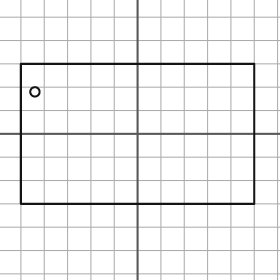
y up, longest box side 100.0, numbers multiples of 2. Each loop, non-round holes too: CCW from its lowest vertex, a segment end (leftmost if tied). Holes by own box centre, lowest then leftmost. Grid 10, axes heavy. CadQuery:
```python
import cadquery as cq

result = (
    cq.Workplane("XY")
    .moveTo(-50.0, -30.0)
    .lineTo(50.0, -30.0)
    .lineTo(50.0, 30.0)
    .lineTo(-50.0, 30.0)
    .close()
    .moveTo(-44.0, 18.0)
    .circle(2.0)
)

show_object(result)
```